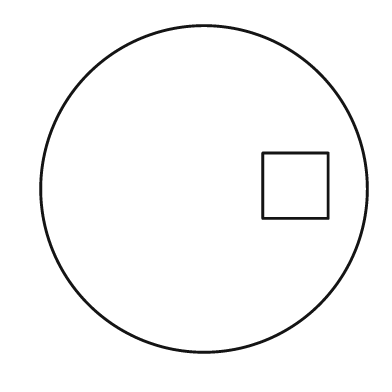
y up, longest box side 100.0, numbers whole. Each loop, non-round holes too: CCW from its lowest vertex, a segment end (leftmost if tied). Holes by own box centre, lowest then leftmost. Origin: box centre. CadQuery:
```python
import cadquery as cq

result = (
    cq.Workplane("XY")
    .moveTo(0.0, 0.0)
    .circle(50.0)
    .moveTo(18.0, -9.0)
    .lineTo(38.0, -9.0)
    .lineTo(38.0, 11.0)
    .lineTo(18.0, 11.0)
    .close()
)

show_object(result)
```